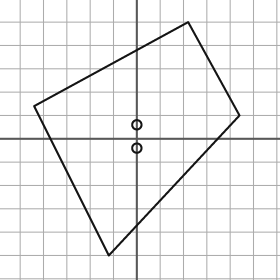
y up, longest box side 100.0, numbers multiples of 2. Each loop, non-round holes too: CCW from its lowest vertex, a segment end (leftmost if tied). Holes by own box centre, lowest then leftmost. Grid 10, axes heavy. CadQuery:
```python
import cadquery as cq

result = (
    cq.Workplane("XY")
    .moveTo(-12.0, -50.0)
    .lineTo(44.0, 10.0)
    .lineTo(22.0, 50.0)
    .lineTo(-44.0, 14.0)
    .close()
    .moveTo(0.0, -4.0)
    .circle(2.0)
    .moveTo(0.0, 6.0)
    .circle(2.0)
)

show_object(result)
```